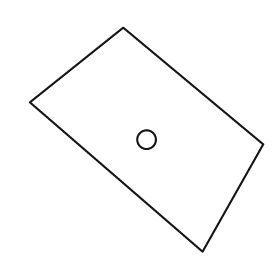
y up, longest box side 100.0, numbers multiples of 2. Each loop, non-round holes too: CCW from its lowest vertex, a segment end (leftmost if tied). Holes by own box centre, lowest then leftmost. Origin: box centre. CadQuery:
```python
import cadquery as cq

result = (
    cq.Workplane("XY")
    .moveTo(24.0, -48.0)
    .lineTo(50.0, -2.0)
    .lineTo(-10.0, 48.0)
    .lineTo(-50.0, 16.0)
    .close()
    .moveTo(0.0, 0.0)
    .circle(4.0)
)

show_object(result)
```